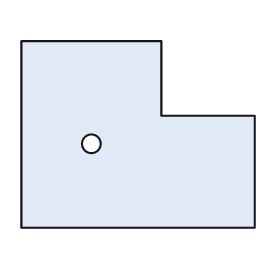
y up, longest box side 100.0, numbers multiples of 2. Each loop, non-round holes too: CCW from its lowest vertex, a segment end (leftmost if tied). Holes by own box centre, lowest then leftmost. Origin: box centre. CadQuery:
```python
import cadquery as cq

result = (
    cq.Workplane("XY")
    .moveTo(-50.0, -40.0)
    .lineTo(50.0, -40.0)
    .lineTo(50.0, 8.0)
    .lineTo(10.0, 8.0)
    .lineTo(10.0, 40.0)
    .lineTo(-50.0, 40.0)
    .close()
    .moveTo(-20.0, -4.0)
    .circle(4.0)
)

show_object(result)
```